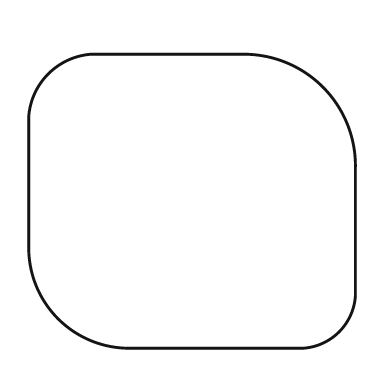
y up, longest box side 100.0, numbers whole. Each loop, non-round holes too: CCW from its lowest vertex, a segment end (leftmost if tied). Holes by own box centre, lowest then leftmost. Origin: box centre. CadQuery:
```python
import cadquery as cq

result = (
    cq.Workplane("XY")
    .moveTo(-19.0, -45.0)
    .lineTo(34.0, -45.0)
    .threePointArc((45.0, -40.0), (50.0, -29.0))
    .lineTo(50.0, 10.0)
    .threePointArc((40.0, 35.0), (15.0, 45.0))
    .lineTo(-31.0, 45.0)
    .threePointArc((-44.0, 39.0), (-50.0, 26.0))
    .lineTo(-50.0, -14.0)
    .threePointArc((-41.0, -36.0), (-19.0, -45.0))
    .close()
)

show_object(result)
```